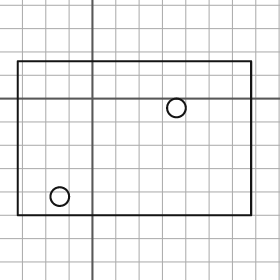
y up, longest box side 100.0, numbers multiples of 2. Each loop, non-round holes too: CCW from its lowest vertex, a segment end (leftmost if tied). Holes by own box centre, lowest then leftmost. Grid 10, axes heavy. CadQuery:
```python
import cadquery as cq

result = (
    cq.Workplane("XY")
    .moveTo(-32.0, -50.0)
    .lineTo(68.0, -50.0)
    .lineTo(68.0, 16.0)
    .lineTo(-32.0, 16.0)
    .close()
    .moveTo(-14.0, -42.0)
    .circle(4.0)
    .moveTo(36.0, -4.0)
    .circle(4.0)
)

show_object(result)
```